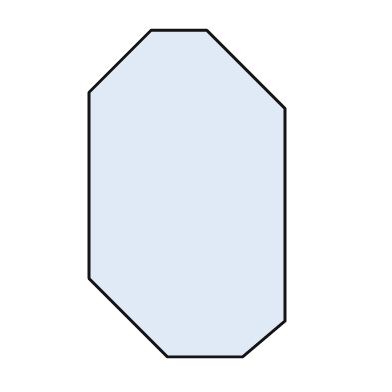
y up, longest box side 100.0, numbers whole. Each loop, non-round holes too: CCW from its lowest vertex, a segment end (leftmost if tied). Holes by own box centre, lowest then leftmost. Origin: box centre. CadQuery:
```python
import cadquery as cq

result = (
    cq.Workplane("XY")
    .moveTo(-6.0, -50.0)
    .lineTo(17.0, -50.0)
    .lineTo(30.0, -39.0)
    .lineTo(30.0, 26.0)
    .lineTo(6.0, 50.0)
    .lineTo(-11.0, 50.0)
    .lineTo(-30.0, 31.0)
    .lineTo(-30.0, -26.0)
    .close()
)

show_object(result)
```